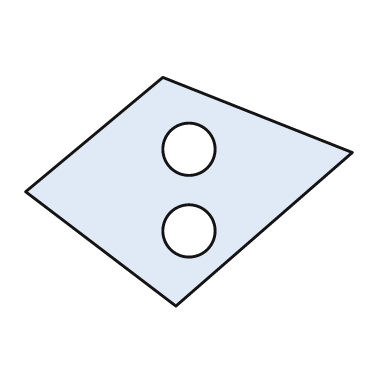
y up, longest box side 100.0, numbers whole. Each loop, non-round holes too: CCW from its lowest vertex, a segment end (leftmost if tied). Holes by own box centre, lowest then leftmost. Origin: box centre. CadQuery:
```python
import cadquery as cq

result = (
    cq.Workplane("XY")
    .moveTo(-4.0, -35.0)
    .lineTo(50.0, 12.0)
    .lineTo(-8.0, 35.0)
    .lineTo(-50.0, 0.0)
    .close()
    .moveTo(0.0, -12.0)
    .circle(8.0)
    .moveTo(0.0, 13.0)
    .circle(8.0)
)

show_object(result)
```